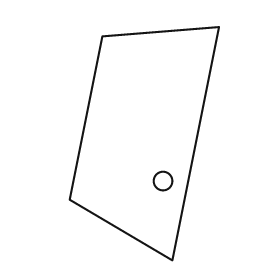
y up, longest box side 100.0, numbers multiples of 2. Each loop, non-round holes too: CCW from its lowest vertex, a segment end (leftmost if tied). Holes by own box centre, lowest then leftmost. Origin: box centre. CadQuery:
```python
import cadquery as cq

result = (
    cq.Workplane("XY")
    .moveTo(12.0, -50.0)
    .lineTo(32.0, 50.0)
    .lineTo(-18.0, 46.0)
    .lineTo(-32.0, -24.0)
    .close()
    .moveTo(8.0, -16.0)
    .circle(4.0)
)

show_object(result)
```